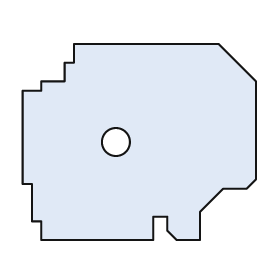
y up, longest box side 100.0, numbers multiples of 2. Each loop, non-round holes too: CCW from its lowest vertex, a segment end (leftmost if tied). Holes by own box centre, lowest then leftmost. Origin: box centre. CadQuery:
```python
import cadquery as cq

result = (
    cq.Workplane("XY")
    .moveTo(-42.0, -42.0)
    .lineTo(6.0, -42.0)
    .lineTo(6.0, -32.0)
    .lineTo(12.0, -32.0)
    .lineTo(12.0, -38.0)
    .lineTo(16.0, -42.0)
    .lineTo(26.0, -42.0)
    .lineTo(26.0, -30.0)
    .lineTo(36.0, -20.0)
    .lineTo(46.0, -20.0)
    .lineTo(50.0, -16.0)
    .lineTo(50.0, 26.0)
    .lineTo(34.0, 42.0)
    .lineTo(-28.0, 42.0)
    .lineTo(-28.0, 34.0)
    .lineTo(-32.0, 34.0)
    .lineTo(-32.0, 26.0)
    .lineTo(-42.0, 26.0)
    .lineTo(-42.0, 22.0)
    .lineTo(-50.0, 22.0)
    .lineTo(-50.0, -18.0)
    .lineTo(-46.0, -18.0)
    .lineTo(-46.0, -34.0)
    .lineTo(-42.0, -34.0)
    .close()
    .moveTo(-10.0, 0.0)
    .circle(6.0)
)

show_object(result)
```